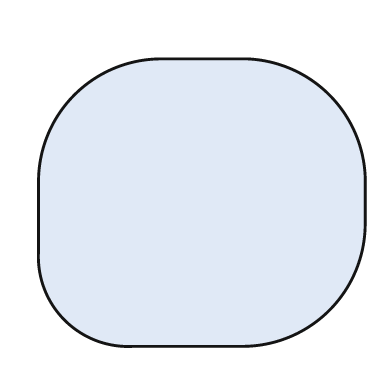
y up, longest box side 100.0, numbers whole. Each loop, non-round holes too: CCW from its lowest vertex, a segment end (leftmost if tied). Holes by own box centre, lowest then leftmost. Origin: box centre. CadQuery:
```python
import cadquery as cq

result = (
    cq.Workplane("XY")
    .moveTo(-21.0, -44.0)
    .lineTo(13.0, -44.0)
    .threePointArc((39.0, -33.0), (50.0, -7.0))
    .lineTo(50.0, 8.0)
    .threePointArc((39.0, 33.0), (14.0, 44.0))
    .lineTo(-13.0, 44.0)
    .threePointArc((-39.0, 33.0), (-50.0, 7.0))
    .lineTo(-50.0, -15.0)
    .threePointArc((-42.0, -36.0), (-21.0, -44.0))
    .close()
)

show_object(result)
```